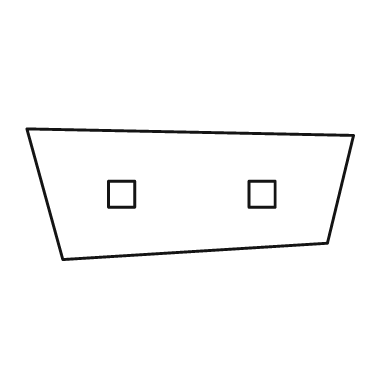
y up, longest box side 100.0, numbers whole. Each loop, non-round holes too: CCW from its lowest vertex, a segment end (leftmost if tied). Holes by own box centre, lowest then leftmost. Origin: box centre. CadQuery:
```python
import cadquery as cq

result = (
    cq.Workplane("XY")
    .moveTo(-39.0, -20.0)
    .lineTo(42.0, -15.0)
    .lineTo(50.0, 18.0)
    .lineTo(-50.0, 20.0)
    .close()
    .moveTo(-25.0, -4.0)
    .lineTo(-17.0, -4.0)
    .lineTo(-17.0, 4.0)
    .lineTo(-25.0, 4.0)
    .close()
    .moveTo(18.0, -4.0)
    .lineTo(26.0, -4.0)
    .lineTo(26.0, 4.0)
    .lineTo(18.0, 4.0)
    .close()
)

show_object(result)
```